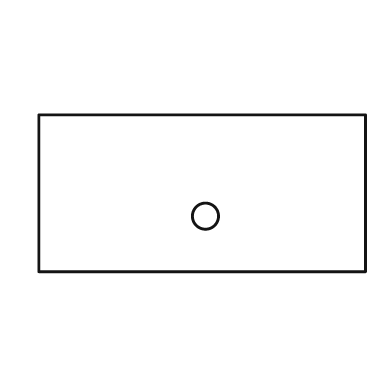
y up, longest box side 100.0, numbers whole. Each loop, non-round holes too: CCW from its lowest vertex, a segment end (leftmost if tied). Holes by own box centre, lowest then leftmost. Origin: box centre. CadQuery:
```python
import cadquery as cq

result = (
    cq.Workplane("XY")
    .moveTo(-50.0, -24.0)
    .lineTo(50.0, -24.0)
    .lineTo(50.0, 24.0)
    .lineTo(-50.0, 24.0)
    .close()
    .moveTo(1.0, -7.0)
    .circle(4.0)
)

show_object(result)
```